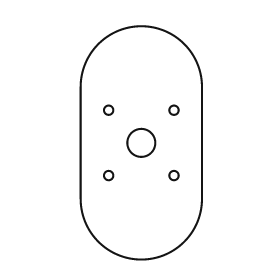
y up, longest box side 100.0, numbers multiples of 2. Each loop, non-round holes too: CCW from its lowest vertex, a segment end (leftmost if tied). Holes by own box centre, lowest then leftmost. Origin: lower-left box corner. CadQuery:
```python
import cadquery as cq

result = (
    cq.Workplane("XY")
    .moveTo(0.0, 26.0)
    .threePointArc((26.0, 0.0), (52.0, 26.0))
    .lineTo(52.0, 74.0)
    .threePointArc((26.0, 100.0), (0.0, 74.0))
    .close()
    .moveTo(12.0, 36.0)
    .circle(2.0)
    .moveTo(40.0, 36.0)
    .circle(2.0)
    .moveTo(26.0, 50.0)
    .circle(6.0)
    .moveTo(12.0, 64.0)
    .circle(2.0)
    .moveTo(40.0, 64.0)
    .circle(2.0)
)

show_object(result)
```